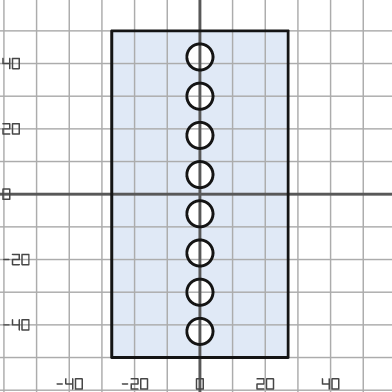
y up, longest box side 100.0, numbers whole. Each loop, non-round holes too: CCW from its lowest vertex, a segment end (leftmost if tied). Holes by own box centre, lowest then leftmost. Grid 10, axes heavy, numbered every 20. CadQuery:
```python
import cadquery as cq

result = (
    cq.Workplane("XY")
    .moveTo(-27.0, -50.0)
    .lineTo(27.0, -50.0)
    .lineTo(27.0, 50.0)
    .lineTo(-27.0, 50.0)
    .close()
    .moveTo(0.0, -42.0)
    .circle(4.0)
    .moveTo(0.0, -30.0)
    .circle(4.0)
    .moveTo(0.0, -18.0)
    .circle(4.0)
    .moveTo(0.0, -6.0)
    .circle(4.0)
    .moveTo(0.0, 6.0)
    .circle(4.0)
    .moveTo(0.0, 18.0)
    .circle(4.0)
    .moveTo(0.0, 30.0)
    .circle(4.0)
    .moveTo(0.0, 42.0)
    .circle(4.0)
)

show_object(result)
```